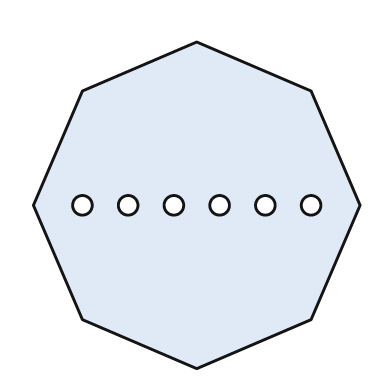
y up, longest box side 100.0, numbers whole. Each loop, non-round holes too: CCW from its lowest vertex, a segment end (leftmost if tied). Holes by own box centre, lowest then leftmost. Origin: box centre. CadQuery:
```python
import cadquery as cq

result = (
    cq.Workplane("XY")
    .moveTo(0.0, -50.0)
    .lineTo(35.0, -35.0)
    .lineTo(50.0, 0.0)
    .lineTo(35.0, 35.0)
    .lineTo(0.0, 50.0)
    .lineTo(-35.0, 35.0)
    .lineTo(-50.0, 0.0)
    .lineTo(-35.0, -35.0)
    .close()
    .moveTo(-35.0, 0.0)
    .circle(3.0)
    .moveTo(-21.0, 0.0)
    .circle(3.0)
    .moveTo(-7.0, 0.0)
    .circle(3.0)
    .moveTo(7.0, 0.0)
    .circle(3.0)
    .moveTo(21.0, 0.0)
    .circle(3.0)
    .moveTo(35.0, 0.0)
    .circle(3.0)
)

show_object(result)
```